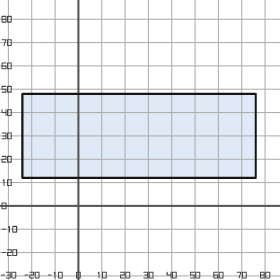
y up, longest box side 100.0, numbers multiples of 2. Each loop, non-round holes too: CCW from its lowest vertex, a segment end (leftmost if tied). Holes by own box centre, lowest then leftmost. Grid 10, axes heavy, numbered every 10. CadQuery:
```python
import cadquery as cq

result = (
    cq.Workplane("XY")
    .moveTo(-24.0, 12.0)
    .lineTo(76.0, 12.0)
    .lineTo(76.0, 48.0)
    .lineTo(-24.0, 48.0)
    .close()
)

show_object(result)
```